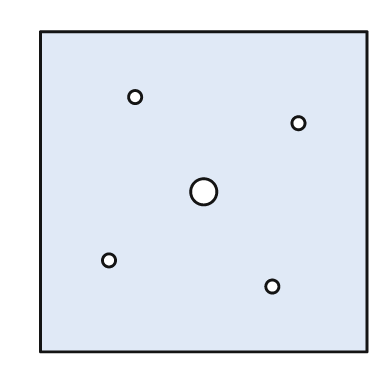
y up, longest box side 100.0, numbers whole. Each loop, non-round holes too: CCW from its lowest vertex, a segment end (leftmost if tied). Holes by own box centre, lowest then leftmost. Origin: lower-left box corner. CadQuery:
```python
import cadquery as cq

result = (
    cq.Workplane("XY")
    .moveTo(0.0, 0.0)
    .lineTo(100.0, 0.0)
    .lineTo(100.0, 98.0)
    .lineTo(0.0, 98.0)
    .close()
    .moveTo(71.0, 20.0)
    .circle(2.0)
    .moveTo(21.0, 28.0)
    .circle(2.0)
    .moveTo(50.0, 49.0)
    .circle(4.0)
    .moveTo(79.0, 70.0)
    .circle(2.0)
    .moveTo(29.0, 78.0)
    .circle(2.0)
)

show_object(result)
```